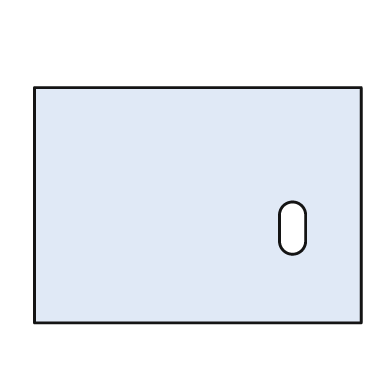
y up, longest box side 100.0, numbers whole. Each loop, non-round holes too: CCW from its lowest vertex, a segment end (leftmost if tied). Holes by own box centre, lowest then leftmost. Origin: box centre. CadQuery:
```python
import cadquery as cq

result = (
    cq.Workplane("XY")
    .moveTo(-50.0, -36.0)
    .lineTo(50.0, -36.0)
    .lineTo(50.0, 36.0)
    .lineTo(-50.0, 36.0)
    .close()
    .moveTo(25.0, -11.0)
    .threePointArc((29.0, -15.0), (33.0, -11.0))
    .lineTo(33.0, -3.0)
    .threePointArc((29.0, 1.0), (25.0, -3.0))
    .close()
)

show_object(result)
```